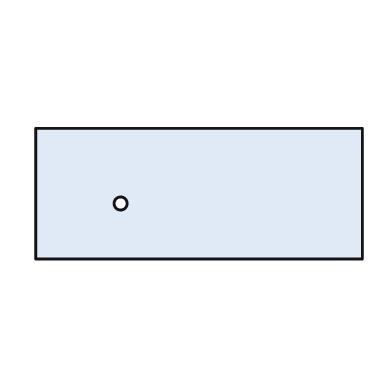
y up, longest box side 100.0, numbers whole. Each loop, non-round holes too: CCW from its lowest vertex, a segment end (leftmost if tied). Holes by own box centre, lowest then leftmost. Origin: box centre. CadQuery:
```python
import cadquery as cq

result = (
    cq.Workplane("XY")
    .moveTo(-50.0, -20.0)
    .lineTo(50.0, -20.0)
    .lineTo(50.0, 20.0)
    .lineTo(-50.0, 20.0)
    .close()
    .moveTo(-24.0, -3.0)
    .circle(2.0)
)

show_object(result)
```